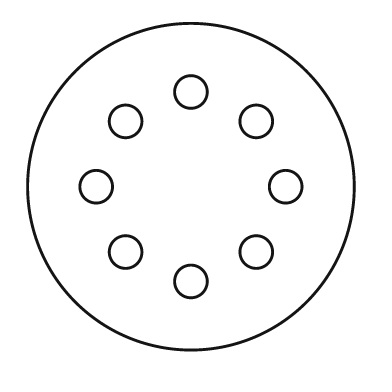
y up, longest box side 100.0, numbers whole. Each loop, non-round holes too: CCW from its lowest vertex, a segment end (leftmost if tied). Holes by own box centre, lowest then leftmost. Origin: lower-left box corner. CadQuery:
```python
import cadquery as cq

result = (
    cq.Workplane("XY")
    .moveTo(50.0, 50.0)
    .circle(50.0)
    .moveTo(50.0, 21.0)
    .circle(5.0)
    .moveTo(30.0, 30.0)
    .circle(5.0)
    .moveTo(70.0, 30.0)
    .circle(5.0)
    .moveTo(21.0, 50.0)
    .circle(5.0)
    .moveTo(79.0, 50.0)
    .circle(5.0)
    .moveTo(30.0, 70.0)
    .circle(5.0)
    .moveTo(70.0, 70.0)
    .circle(5.0)
    .moveTo(50.0, 79.0)
    .circle(5.0)
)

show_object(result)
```